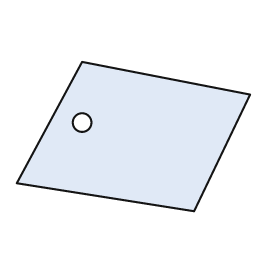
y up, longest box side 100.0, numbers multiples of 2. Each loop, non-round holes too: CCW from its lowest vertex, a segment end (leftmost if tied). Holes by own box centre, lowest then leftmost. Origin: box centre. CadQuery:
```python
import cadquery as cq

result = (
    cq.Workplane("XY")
    .moveTo(26.0, -32.0)
    .lineTo(50.0, 18.0)
    .lineTo(-22.0, 32.0)
    .lineTo(-50.0, -20.0)
    .close()
    .moveTo(-22.0, 6.0)
    .circle(4.0)
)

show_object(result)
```